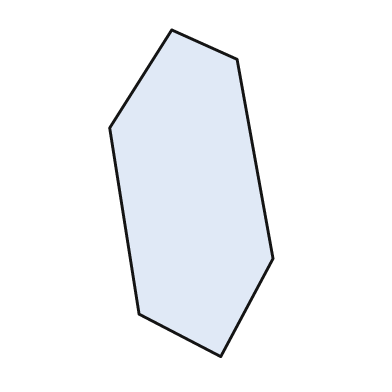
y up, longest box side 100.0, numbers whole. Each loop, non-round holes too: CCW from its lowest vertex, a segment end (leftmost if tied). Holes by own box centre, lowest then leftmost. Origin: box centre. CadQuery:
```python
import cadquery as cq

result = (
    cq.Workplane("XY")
    .moveTo(9.0, -50.0)
    .lineTo(25.0, -20.0)
    .lineTo(14.0, 41.0)
    .lineTo(-6.0, 50.0)
    .lineTo(-25.0, 20.0)
    .lineTo(-16.0, -37.0)
    .close()
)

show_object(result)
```